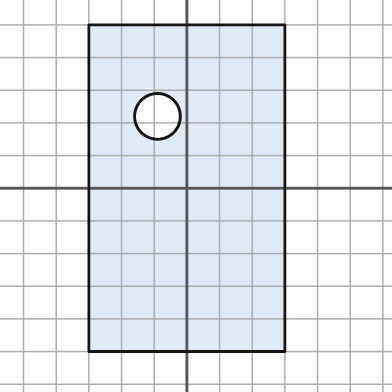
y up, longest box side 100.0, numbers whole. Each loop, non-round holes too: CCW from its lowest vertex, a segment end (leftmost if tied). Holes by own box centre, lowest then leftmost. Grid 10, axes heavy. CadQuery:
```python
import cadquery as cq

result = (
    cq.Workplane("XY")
    .moveTo(-30.0, -50.0)
    .lineTo(30.0, -50.0)
    .lineTo(30.0, 50.0)
    .lineTo(-30.0, 50.0)
    .close()
    .moveTo(-9.0, 22.0)
    .circle(7.0)
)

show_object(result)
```